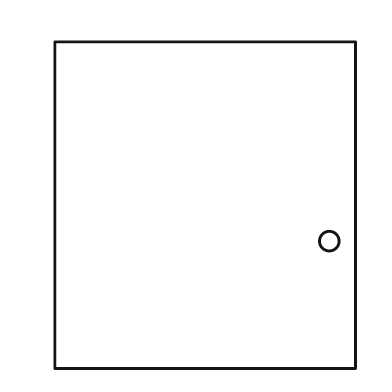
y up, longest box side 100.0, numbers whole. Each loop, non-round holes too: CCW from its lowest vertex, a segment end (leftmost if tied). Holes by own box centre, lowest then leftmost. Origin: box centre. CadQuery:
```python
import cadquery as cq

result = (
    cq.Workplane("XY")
    .moveTo(-46.0, -50.0)
    .lineTo(46.0, -50.0)
    .lineTo(46.0, 50.0)
    .lineTo(-46.0, 50.0)
    .close()
    .moveTo(38.0, -11.0)
    .circle(3.0)
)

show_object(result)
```